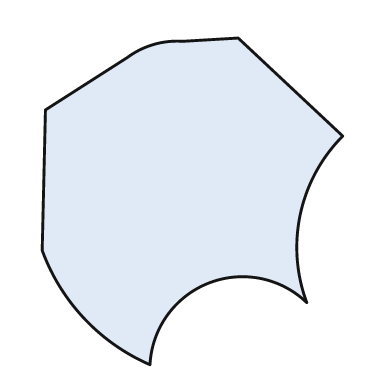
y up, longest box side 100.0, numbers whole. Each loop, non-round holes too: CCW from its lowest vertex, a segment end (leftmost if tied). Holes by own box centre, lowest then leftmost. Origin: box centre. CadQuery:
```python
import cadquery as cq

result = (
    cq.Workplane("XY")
    .moveTo(-13.0, -50.0)
    .threePointArc((5.0, -25.0), (35.0, -31.0))
    .threePointArc((33.0, -4.0), (46.0, 20.0))
    .lineTo(14.0, 50.0)
    .lineTo(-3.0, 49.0)
    .threePointArc((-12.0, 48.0), (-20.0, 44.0))
    .lineTo(-45.0, 28.0)
    .lineTo(-46.0, -15.0)
    .threePointArc((-33.0, -36.0), (-13.0, -50.0))
    .close()
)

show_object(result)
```